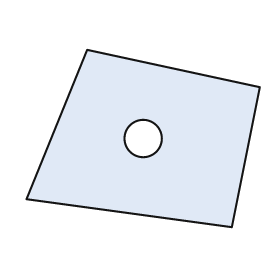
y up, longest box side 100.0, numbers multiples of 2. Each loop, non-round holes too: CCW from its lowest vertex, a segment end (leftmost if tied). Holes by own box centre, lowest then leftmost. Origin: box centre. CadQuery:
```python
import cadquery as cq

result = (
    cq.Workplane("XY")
    .moveTo(38.0, -38.0)
    .lineTo(50.0, 22.0)
    .lineTo(-24.0, 38.0)
    .lineTo(-50.0, -26.0)
    .close()
    .moveTo(0.0, 0.0)
    .circle(8.0)
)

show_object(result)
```